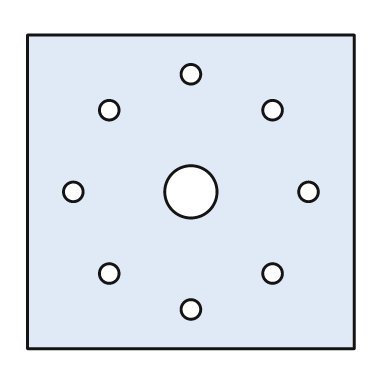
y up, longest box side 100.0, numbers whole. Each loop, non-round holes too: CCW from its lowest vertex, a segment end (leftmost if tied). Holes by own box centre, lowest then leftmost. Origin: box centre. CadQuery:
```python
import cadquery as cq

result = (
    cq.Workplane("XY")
    .moveTo(-50.0, -48.0)
    .lineTo(50.0, -48.0)
    .lineTo(50.0, 48.0)
    .lineTo(-50.0, 48.0)
    .close()
    .moveTo(0.0, -36.0)
    .circle(3.0)
    .moveTo(-25.0, -25.0)
    .circle(3.0)
    .moveTo(25.0, -25.0)
    .circle(3.0)
    .moveTo(-36.0, 0.0)
    .circle(3.0)
    .moveTo(0.0, 0.0)
    .circle(8.0)
    .moveTo(36.0, 0.0)
    .circle(3.0)
    .moveTo(-25.0, 25.0)
    .circle(3.0)
    .moveTo(25.0, 25.0)
    .circle(3.0)
    .moveTo(0.0, 36.0)
    .circle(3.0)
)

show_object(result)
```